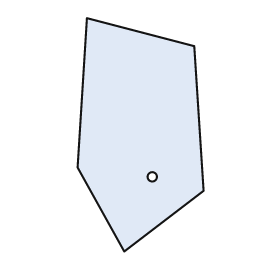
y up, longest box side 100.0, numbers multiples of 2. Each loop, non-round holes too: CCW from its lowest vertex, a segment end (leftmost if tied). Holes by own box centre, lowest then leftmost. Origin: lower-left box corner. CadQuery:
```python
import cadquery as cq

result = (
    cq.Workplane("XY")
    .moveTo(20.0, 0.0)
    .lineTo(54.0, 26.0)
    .lineTo(50.0, 88.0)
    .lineTo(4.0, 100.0)
    .lineTo(0.0, 36.0)
    .close()
    .moveTo(32.0, 32.0)
    .circle(2.0)
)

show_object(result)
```